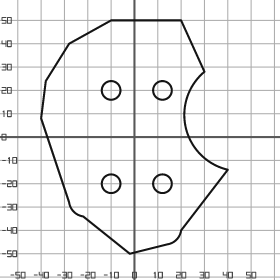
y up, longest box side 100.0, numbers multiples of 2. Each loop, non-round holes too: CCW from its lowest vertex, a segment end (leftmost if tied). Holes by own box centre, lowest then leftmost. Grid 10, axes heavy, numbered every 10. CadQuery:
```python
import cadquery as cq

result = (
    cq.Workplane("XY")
    .moveTo(-2.0, -50.0)
    .lineTo(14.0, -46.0)
    .threePointArc((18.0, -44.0), (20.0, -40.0))
    .lineTo(40.0, -14.0)
    .threePointArc((22.0, 4.0), (30.0, 28.0))
    .lineTo(20.0, 50.0)
    .lineTo(-10.0, 50.0)
    .lineTo(-28.0, 40.0)
    .lineTo(-38.0, 24.0)
    .lineTo(-40.0, 8.0)
    .lineTo(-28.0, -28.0)
    .threePointArc((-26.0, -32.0), (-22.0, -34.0))
    .close()
    .moveTo(-10.0, -20.0)
    .circle(4.0)
    .moveTo(12.0, -20.0)
    .circle(4.0)
    .moveTo(-10.0, 20.0)
    .circle(4.0)
    .moveTo(12.0, 20.0)
    .circle(4.0)
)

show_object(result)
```